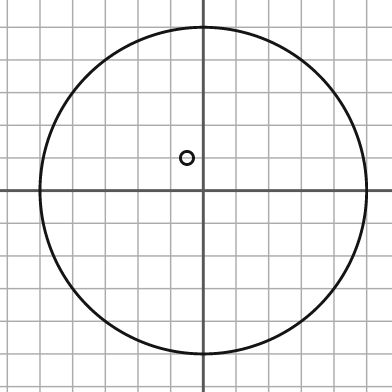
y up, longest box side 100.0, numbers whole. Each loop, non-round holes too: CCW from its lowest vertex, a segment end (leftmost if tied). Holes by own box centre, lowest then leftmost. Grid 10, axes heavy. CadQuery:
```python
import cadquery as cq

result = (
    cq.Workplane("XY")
    .moveTo(0.0, 0.0)
    .circle(50.0)
    .moveTo(-5.0, 10.0)
    .circle(2.0)
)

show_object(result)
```